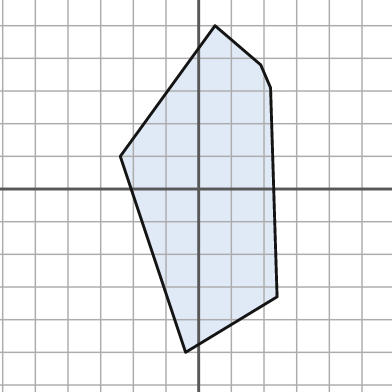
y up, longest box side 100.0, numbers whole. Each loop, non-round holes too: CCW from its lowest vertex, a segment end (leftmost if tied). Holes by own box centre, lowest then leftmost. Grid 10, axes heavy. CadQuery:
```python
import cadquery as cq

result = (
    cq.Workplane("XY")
    .moveTo(-4.0, -50.0)
    .lineTo(24.0, -33.0)
    .lineTo(22.0, 31.0)
    .lineTo(19.0, 38.0)
    .lineTo(5.0, 50.0)
    .lineTo(-24.0, 10.0)
    .close()
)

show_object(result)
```